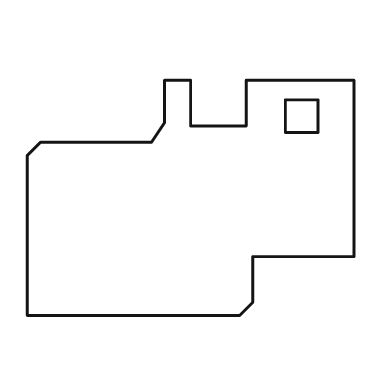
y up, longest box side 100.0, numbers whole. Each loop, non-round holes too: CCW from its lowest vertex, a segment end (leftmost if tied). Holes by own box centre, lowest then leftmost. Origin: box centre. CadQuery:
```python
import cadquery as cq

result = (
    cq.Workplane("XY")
    .moveTo(-50.0, -36.0)
    .lineTo(15.0, -36.0)
    .lineTo(19.0, -32.0)
    .lineTo(19.0, -18.0)
    .lineTo(50.0, -18.0)
    .lineTo(50.0, 36.0)
    .lineTo(17.0, 36.0)
    .lineTo(17.0, 22.0)
    .lineTo(0.0, 22.0)
    .lineTo(0.0, 36.0)
    .lineTo(-8.0, 36.0)
    .lineTo(-8.0, 23.0)
    .lineTo(-12.0, 17.0)
    .lineTo(-46.0, 17.0)
    .lineTo(-50.0, 13.0)
    .close()
    .moveTo(29.0, 20.0)
    .lineTo(39.0, 20.0)
    .lineTo(39.0, 30.0)
    .lineTo(29.0, 30.0)
    .close()
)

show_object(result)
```